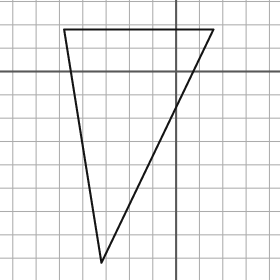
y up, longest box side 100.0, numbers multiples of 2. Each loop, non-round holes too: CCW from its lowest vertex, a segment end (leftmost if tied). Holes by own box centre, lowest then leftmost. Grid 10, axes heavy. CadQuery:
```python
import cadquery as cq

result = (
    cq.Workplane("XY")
    .moveTo(-32.0, -82.0)
    .lineTo(16.0, 18.0)
    .lineTo(-48.0, 18.0)
    .close()
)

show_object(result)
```